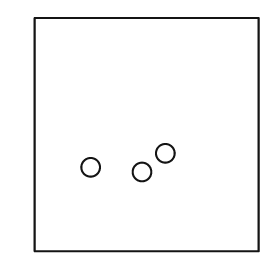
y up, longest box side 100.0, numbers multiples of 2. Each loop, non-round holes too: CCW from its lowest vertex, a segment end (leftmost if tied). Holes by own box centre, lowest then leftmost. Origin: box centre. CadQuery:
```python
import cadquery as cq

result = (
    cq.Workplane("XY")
    .moveTo(-48.0, -50.0)
    .lineTo(48.0, -50.0)
    .lineTo(48.0, 50.0)
    .lineTo(-48.0, 50.0)
    .close()
    .moveTo(-2.0, -16.0)
    .circle(4.0)
    .moveTo(-24.0, -14.0)
    .circle(4.0)
    .moveTo(8.0, -8.0)
    .circle(4.0)
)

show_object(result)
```